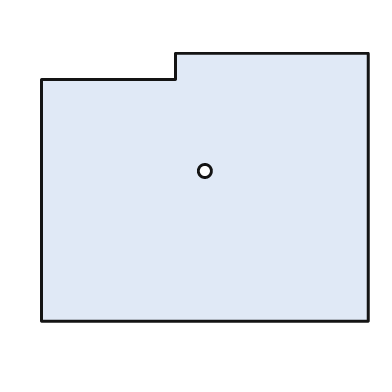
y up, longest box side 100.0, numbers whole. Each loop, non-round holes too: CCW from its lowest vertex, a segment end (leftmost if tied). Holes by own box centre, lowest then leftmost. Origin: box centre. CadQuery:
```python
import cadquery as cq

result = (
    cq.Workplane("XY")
    .moveTo(-50.0, -41.0)
    .lineTo(50.0, -41.0)
    .lineTo(50.0, 41.0)
    .lineTo(-9.0, 41.0)
    .lineTo(-9.0, 33.0)
    .lineTo(-50.0, 33.0)
    .close()
    .moveTo(0.0, 5.0)
    .circle(2.0)
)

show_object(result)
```